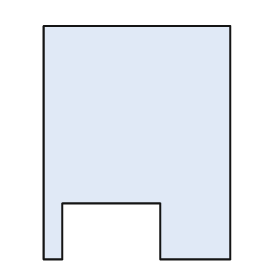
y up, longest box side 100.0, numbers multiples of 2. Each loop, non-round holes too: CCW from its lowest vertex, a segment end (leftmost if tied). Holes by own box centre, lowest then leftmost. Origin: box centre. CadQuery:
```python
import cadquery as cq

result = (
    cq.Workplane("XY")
    .moveTo(-40.0, -50.0)
    .lineTo(-32.0, -50.0)
    .lineTo(-32.0, -26.0)
    .lineTo(10.0, -26.0)
    .lineTo(10.0, -50.0)
    .lineTo(40.0, -50.0)
    .lineTo(40.0, 50.0)
    .lineTo(-40.0, 50.0)
    .close()
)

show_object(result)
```